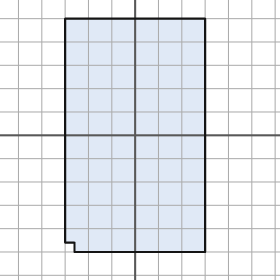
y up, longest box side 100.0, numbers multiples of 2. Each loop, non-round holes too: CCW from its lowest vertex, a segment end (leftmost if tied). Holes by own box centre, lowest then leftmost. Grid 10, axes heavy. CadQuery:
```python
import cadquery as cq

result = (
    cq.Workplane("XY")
    .moveTo(-26.0, -50.0)
    .lineTo(30.0, -50.0)
    .lineTo(30.0, 50.0)
    .lineTo(-30.0, 50.0)
    .lineTo(-30.0, -46.0)
    .lineTo(-26.0, -46.0)
    .close()
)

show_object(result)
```